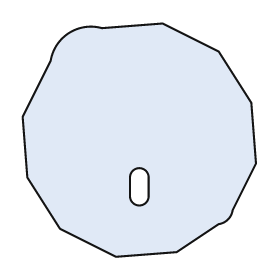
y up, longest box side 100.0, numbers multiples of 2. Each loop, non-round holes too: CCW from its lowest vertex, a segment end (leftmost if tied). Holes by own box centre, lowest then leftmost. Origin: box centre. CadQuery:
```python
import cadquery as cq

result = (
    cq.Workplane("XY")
    .moveTo(-10.0, -50.0)
    .lineTo(16.0, -48.0)
    .lineTo(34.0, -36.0)
    .threePointArc((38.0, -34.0), (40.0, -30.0))
    .lineTo(50.0, -10.0)
    .lineTo(48.0, 16.0)
    .lineTo(34.0, 38.0)
    .lineTo(10.0, 50.0)
    .lineTo(-16.0, 48.0)
    .threePointArc((-30.0, 46.0), (-38.0, 34.0))
    .lineTo(-50.0, 10.0)
    .lineTo(-48.0, -16.0)
    .lineTo(-34.0, -38.0)
    .close()
    .moveTo(-4.0, -24.0)
    .threePointArc((0.0, -28.0), (4.0, -24.0))
    .lineTo(4.0, -16.0)
    .threePointArc((0.0, -12.0), (-4.0, -16.0))
    .close()
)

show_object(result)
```